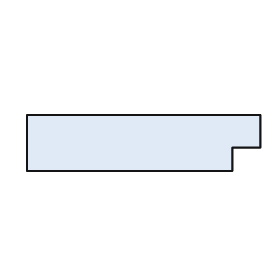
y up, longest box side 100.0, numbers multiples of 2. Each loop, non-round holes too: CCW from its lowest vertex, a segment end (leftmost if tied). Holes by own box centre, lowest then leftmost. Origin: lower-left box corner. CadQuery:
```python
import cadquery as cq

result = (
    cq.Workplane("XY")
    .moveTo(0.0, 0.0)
    .lineTo(88.0, 0.0)
    .lineTo(88.0, 10.0)
    .lineTo(100.0, 10.0)
    .lineTo(100.0, 24.0)
    .lineTo(0.0, 24.0)
    .close()
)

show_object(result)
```